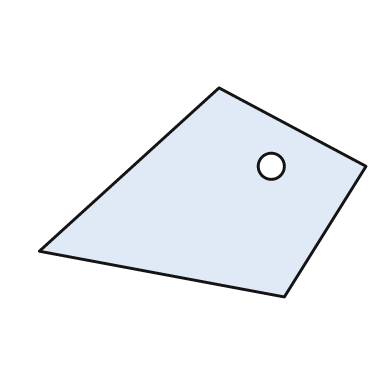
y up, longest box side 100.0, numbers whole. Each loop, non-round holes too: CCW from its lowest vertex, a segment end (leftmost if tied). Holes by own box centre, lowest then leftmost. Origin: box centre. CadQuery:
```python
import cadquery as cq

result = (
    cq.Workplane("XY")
    .moveTo(25.0, -32.0)
    .lineTo(50.0, 8.0)
    .lineTo(5.0, 32.0)
    .lineTo(-50.0, -18.0)
    .close()
    .moveTo(21.0, 8.0)
    .circle(4.0)
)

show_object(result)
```